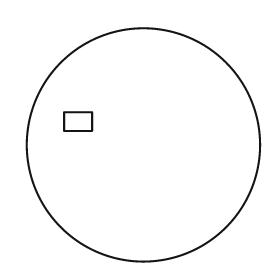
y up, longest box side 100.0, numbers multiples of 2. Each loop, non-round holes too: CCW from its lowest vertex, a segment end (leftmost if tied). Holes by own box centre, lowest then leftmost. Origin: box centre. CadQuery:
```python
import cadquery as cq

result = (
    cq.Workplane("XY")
    .moveTo(0.0, 0.0)
    .circle(50.0)
    .moveTo(-34.0, 6.0)
    .lineTo(-22.0, 6.0)
    .lineTo(-22.0, 14.0)
    .lineTo(-34.0, 14.0)
    .close()
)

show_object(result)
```